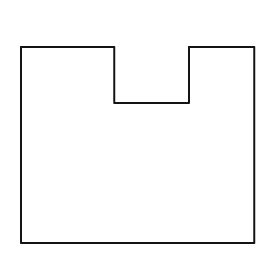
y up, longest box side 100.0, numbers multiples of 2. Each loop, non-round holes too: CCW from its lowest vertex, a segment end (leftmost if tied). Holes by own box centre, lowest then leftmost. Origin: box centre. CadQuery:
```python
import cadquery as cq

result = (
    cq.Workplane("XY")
    .moveTo(-50.0, -42.0)
    .lineTo(50.0, -42.0)
    .lineTo(50.0, 42.0)
    .lineTo(22.0, 42.0)
    .lineTo(22.0, 18.0)
    .lineTo(-10.0, 18.0)
    .lineTo(-10.0, 42.0)
    .lineTo(-50.0, 42.0)
    .close()
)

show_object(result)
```